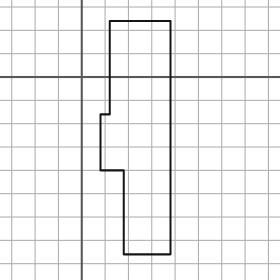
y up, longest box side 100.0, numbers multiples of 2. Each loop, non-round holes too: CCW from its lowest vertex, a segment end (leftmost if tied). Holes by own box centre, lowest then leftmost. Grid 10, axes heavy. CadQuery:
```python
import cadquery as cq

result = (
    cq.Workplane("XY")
    .moveTo(18.0, -76.0)
    .lineTo(38.0, -76.0)
    .lineTo(38.0, 24.0)
    .lineTo(12.0, 24.0)
    .lineTo(12.0, -16.0)
    .lineTo(8.0, -16.0)
    .lineTo(8.0, -40.0)
    .lineTo(18.0, -40.0)
    .close()
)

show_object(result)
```